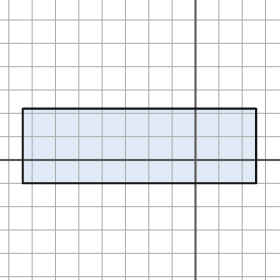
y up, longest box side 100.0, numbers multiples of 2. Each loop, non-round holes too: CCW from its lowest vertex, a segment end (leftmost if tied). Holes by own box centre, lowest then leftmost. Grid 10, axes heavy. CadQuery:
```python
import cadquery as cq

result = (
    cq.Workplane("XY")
    .moveTo(-74.0, -10.0)
    .lineTo(26.0, -10.0)
    .lineTo(26.0, 22.0)
    .lineTo(-74.0, 22.0)
    .close()
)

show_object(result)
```